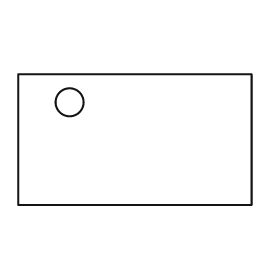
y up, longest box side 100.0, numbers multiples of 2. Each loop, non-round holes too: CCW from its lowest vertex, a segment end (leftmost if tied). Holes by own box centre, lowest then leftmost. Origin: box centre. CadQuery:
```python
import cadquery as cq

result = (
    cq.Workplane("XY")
    .moveTo(-50.0, -28.0)
    .lineTo(50.0, -28.0)
    .lineTo(50.0, 28.0)
    .lineTo(-50.0, 28.0)
    .close()
    .moveTo(-28.0, 16.0)
    .circle(6.0)
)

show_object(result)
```